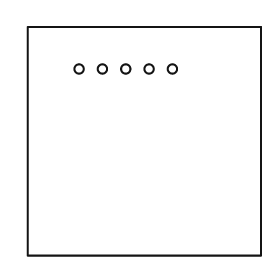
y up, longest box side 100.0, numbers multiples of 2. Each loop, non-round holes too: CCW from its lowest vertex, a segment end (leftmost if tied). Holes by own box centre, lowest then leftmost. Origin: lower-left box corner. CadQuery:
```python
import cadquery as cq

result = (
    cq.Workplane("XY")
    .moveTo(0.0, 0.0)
    .lineTo(100.0, 0.0)
    .lineTo(100.0, 98.0)
    .lineTo(0.0, 98.0)
    .close()
    .moveTo(22.0, 80.0)
    .circle(2.0)
    .moveTo(32.0, 80.0)
    .circle(2.0)
    .moveTo(42.0, 80.0)
    .circle(2.0)
    .moveTo(52.0, 80.0)
    .circle(2.0)
    .moveTo(62.0, 80.0)
    .circle(2.0)
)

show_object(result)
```